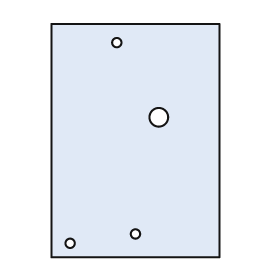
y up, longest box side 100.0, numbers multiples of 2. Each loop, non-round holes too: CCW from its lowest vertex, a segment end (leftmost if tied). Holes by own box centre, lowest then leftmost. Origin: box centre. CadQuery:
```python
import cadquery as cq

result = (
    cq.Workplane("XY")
    .moveTo(-36.0, -50.0)
    .lineTo(36.0, -50.0)
    .lineTo(36.0, 50.0)
    .lineTo(-36.0, 50.0)
    .close()
    .moveTo(-28.0, -44.0)
    .circle(2.0)
    .moveTo(0.0, -40.0)
    .circle(2.0)
    .moveTo(10.0, 10.0)
    .circle(4.0)
    .moveTo(-8.0, 42.0)
    .circle(2.0)
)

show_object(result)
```